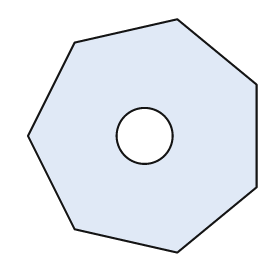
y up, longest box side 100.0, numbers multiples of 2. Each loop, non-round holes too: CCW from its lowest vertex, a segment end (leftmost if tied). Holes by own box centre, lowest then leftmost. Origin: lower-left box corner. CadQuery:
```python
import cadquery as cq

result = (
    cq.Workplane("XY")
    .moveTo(64.0, 0.0)
    .lineTo(98.0, 28.0)
    .lineTo(98.0, 72.0)
    .lineTo(64.0, 100.0)
    .lineTo(20.0, 90.0)
    .lineTo(0.0, 50.0)
    .lineTo(20.0, 10.0)
    .close()
    .moveTo(50.0, 50.0)
    .circle(12.0)
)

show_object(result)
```